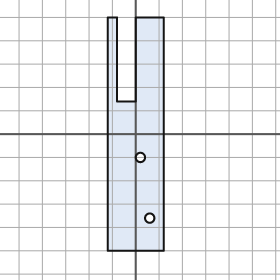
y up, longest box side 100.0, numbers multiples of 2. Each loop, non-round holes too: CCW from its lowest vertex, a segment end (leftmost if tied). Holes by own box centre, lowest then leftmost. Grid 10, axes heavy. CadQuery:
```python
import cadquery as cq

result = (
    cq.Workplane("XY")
    .moveTo(-12.0, -50.0)
    .lineTo(12.0, -50.0)
    .lineTo(12.0, 50.0)
    .lineTo(0.0, 50.0)
    .lineTo(0.0, 14.0)
    .lineTo(-8.0, 14.0)
    .lineTo(-8.0, 50.0)
    .lineTo(-12.0, 50.0)
    .close()
    .moveTo(6.0, -36.0)
    .circle(2.0)
    .moveTo(2.0, -10.0)
    .circle(2.0)
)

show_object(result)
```